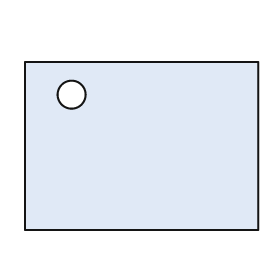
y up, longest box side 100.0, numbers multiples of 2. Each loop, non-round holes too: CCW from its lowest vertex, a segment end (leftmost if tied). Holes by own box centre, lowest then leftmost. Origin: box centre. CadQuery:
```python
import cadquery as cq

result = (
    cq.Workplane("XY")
    .moveTo(-50.0, -36.0)
    .lineTo(50.0, -36.0)
    .lineTo(50.0, 36.0)
    .lineTo(-50.0, 36.0)
    .close()
    .moveTo(-30.0, 22.0)
    .circle(6.0)
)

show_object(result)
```